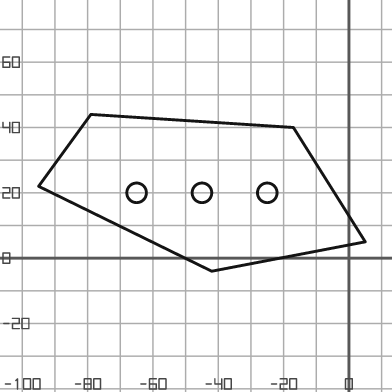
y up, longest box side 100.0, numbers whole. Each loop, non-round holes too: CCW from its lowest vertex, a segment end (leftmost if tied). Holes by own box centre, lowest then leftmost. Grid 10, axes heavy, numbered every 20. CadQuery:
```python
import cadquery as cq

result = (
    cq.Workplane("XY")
    .moveTo(-42.0, -4.0)
    .lineTo(5.0, 5.0)
    .lineTo(-17.0, 40.0)
    .lineTo(-79.0, 44.0)
    .lineTo(-95.0, 22.0)
    .close()
    .moveTo(-65.0, 20.0)
    .circle(3.0)
    .moveTo(-45.0, 20.0)
    .circle(3.0)
    .moveTo(-25.0, 20.0)
    .circle(3.0)
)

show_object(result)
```